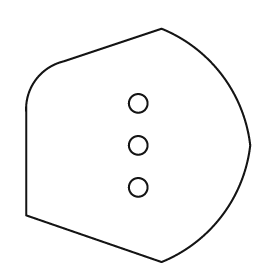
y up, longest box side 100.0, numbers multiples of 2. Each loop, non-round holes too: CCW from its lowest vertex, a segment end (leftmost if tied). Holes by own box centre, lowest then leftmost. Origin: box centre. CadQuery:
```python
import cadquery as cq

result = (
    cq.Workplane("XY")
    .moveTo(10.0, -50.0)
    .threePointArc((36.0, -30.0), (48.0, 0.0))
    .threePointArc((36.0, 30.0), (10.0, 50.0))
    .lineTo(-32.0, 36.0)
    .threePointArc((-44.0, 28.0), (-48.0, 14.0))
    .lineTo(-48.0, -30.0)
    .close()
    .moveTo(0.0, -18.0)
    .circle(4.0)
    .moveTo(0.0, 0.0)
    .circle(4.0)
    .moveTo(0.0, 18.0)
    .circle(4.0)
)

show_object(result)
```